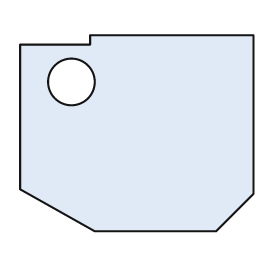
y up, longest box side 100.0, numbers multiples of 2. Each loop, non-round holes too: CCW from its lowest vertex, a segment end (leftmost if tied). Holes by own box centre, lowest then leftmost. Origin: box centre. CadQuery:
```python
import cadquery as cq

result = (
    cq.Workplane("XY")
    .moveTo(-18.0, -42.0)
    .lineTo(34.0, -42.0)
    .lineTo(50.0, -26.0)
    .lineTo(50.0, 42.0)
    .lineTo(-20.0, 42.0)
    .lineTo(-20.0, 38.0)
    .lineTo(-50.0, 38.0)
    .lineTo(-50.0, -24.0)
    .close()
    .moveTo(-28.0, 22.0)
    .circle(10.0)
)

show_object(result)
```